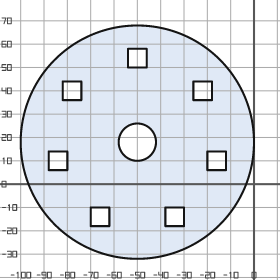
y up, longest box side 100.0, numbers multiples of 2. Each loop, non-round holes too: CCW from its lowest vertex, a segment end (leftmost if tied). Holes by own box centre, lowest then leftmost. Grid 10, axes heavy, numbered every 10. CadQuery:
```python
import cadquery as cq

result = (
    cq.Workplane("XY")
    .moveTo(-50.0, 18.0)
    .circle(50.0)
    .moveTo(-70.0, -18.0)
    .lineTo(-62.0, -18.0)
    .lineTo(-62.0, -10.0)
    .lineTo(-70.0, -10.0)
    .close()
    .moveTo(-38.0, -18.0)
    .lineTo(-30.0, -18.0)
    .lineTo(-30.0, -10.0)
    .lineTo(-38.0, -10.0)
    .close()
    .moveTo(-88.0, 6.0)
    .lineTo(-80.0, 6.0)
    .lineTo(-80.0, 14.0)
    .lineTo(-88.0, 14.0)
    .close()
    .moveTo(-20.0, 6.0)
    .lineTo(-12.0, 6.0)
    .lineTo(-12.0, 14.0)
    .lineTo(-20.0, 14.0)
    .close()
    .moveTo(-50.0, 18.0)
    .circle(8.0)
    .moveTo(-82.0, 36.0)
    .lineTo(-74.0, 36.0)
    .lineTo(-74.0, 44.0)
    .lineTo(-82.0, 44.0)
    .close()
    .moveTo(-26.0, 36.0)
    .lineTo(-18.0, 36.0)
    .lineTo(-18.0, 44.0)
    .lineTo(-26.0, 44.0)
    .close()
    .moveTo(-54.0, 50.0)
    .lineTo(-46.0, 50.0)
    .lineTo(-46.0, 58.0)
    .lineTo(-54.0, 58.0)
    .close()
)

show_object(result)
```